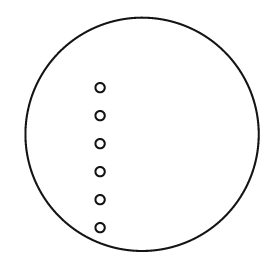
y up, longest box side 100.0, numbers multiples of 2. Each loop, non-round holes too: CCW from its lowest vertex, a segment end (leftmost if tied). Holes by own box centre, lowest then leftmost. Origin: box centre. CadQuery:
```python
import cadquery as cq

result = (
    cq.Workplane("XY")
    .moveTo(0.0, 0.0)
    .circle(50.0)
    .moveTo(-18.0, -40.0)
    .circle(2.0)
    .moveTo(-18.0, -28.0)
    .circle(2.0)
    .moveTo(-18.0, -16.0)
    .circle(2.0)
    .moveTo(-18.0, -4.0)
    .circle(2.0)
    .moveTo(-18.0, 8.0)
    .circle(2.0)
    .moveTo(-18.0, 20.0)
    .circle(2.0)
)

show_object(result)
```